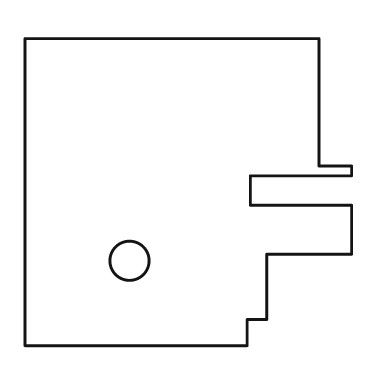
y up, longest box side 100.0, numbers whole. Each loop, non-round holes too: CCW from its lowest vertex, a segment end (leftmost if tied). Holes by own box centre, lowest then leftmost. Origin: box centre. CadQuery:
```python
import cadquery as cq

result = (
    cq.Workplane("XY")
    .moveTo(-50.0, -47.0)
    .lineTo(18.0, -47.0)
    .lineTo(18.0, -39.0)
    .lineTo(24.0, -39.0)
    .lineTo(24.0, -19.0)
    .lineTo(50.0, -19.0)
    .lineTo(50.0, -4.0)
    .lineTo(19.0, -4.0)
    .lineTo(19.0, 5.0)
    .lineTo(50.0, 5.0)
    .lineTo(50.0, 8.0)
    .lineTo(40.0, 8.0)
    .lineTo(40.0, 47.0)
    .lineTo(-50.0, 47.0)
    .close()
    .moveTo(-18.0, -21.0)
    .circle(6.0)
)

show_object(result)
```